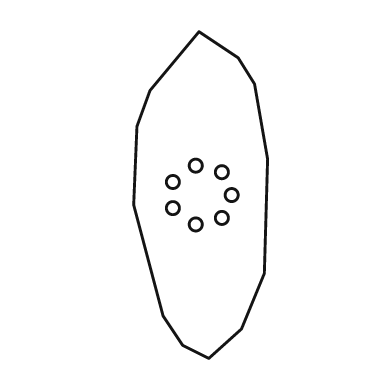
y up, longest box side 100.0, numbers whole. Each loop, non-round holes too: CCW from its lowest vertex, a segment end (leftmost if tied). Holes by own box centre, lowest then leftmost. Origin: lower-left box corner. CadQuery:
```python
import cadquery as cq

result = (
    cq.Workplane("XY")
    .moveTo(23.0, 0.0)
    .lineTo(33.0, 9.0)
    .lineTo(40.0, 26.0)
    .lineTo(41.0, 61.0)
    .lineTo(37.0, 84.0)
    .lineTo(32.0, 92.0)
    .lineTo(20.0, 100.0)
    .lineTo(5.0, 82.0)
    .lineTo(1.0, 71.0)
    .lineTo(0.0, 47.0)
    .lineTo(9.0, 13.0)
    .lineTo(15.0, 4.0)
    .close()
    .moveTo(19.0, 41.0)
    .circle(2.0)
    .moveTo(27.0, 43.0)
    .circle(2.0)
    .moveTo(12.0, 46.0)
    .circle(2.0)
    .moveTo(30.0, 50.0)
    .circle(2.0)
    .moveTo(12.0, 54.0)
    .circle(2.0)
    .moveTo(27.0, 57.0)
    .circle(2.0)
    .moveTo(19.0, 59.0)
    .circle(2.0)
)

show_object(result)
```